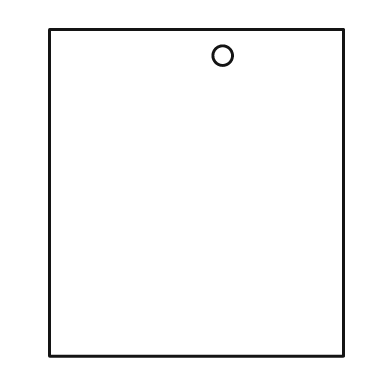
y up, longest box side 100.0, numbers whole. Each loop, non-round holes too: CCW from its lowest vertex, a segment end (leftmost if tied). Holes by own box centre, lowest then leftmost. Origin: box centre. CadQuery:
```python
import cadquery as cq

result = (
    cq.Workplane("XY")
    .moveTo(-45.0, -50.0)
    .lineTo(45.0, -50.0)
    .lineTo(45.0, 50.0)
    .lineTo(-45.0, 50.0)
    .close()
    .moveTo(8.0, 42.0)
    .circle(3.0)
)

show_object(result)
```